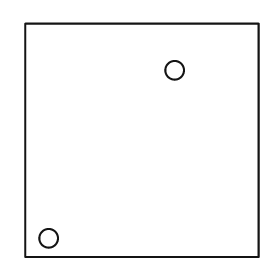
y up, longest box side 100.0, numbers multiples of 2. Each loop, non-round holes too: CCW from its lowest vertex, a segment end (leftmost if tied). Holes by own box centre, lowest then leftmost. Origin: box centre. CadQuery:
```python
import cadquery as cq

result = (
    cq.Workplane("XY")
    .moveTo(-50.0, -50.0)
    .lineTo(50.0, -50.0)
    .lineTo(50.0, 50.0)
    .lineTo(-50.0, 50.0)
    .close()
    .moveTo(-40.0, -42.0)
    .circle(4.0)
    .moveTo(14.0, 30.0)
    .circle(4.0)
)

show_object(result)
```